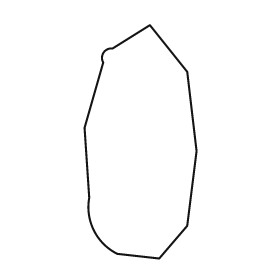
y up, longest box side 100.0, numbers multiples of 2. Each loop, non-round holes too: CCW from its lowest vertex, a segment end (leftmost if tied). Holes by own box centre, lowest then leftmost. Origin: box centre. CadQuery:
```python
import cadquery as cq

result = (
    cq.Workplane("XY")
    .moveTo(8.0, -50.0)
    .lineTo(20.0, -36.0)
    .lineTo(24.0, -4.0)
    .lineTo(20.0, 30.0)
    .lineTo(4.0, 50.0)
    .lineTo(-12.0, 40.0)
    .threePointArc((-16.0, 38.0), (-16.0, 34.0))
    .lineTo(-24.0, 6.0)
    .lineTo(-22.0, -24.0)
    .threePointArc((-20.0, -38.0), (-10.0, -48.0))
    .close()
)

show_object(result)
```